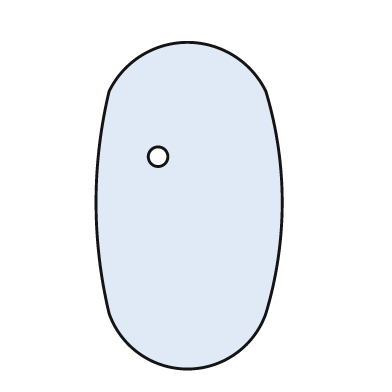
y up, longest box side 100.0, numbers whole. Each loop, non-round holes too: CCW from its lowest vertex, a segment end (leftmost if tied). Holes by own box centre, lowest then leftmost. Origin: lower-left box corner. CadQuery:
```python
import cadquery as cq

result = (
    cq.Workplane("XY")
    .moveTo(4.0, 17.0)
    .threePointArc((28.0, 0.0), (52.0, 17.0))
    .threePointArc((57.0, 51.0), (52.0, 85.0))
    .threePointArc((28.0, 100.0), (4.0, 85.0))
    .threePointArc((0.0, 51.0), (4.0, 17.0))
    .close()
    .moveTo(19.0, 65.0)
    .circle(3.0)
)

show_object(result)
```